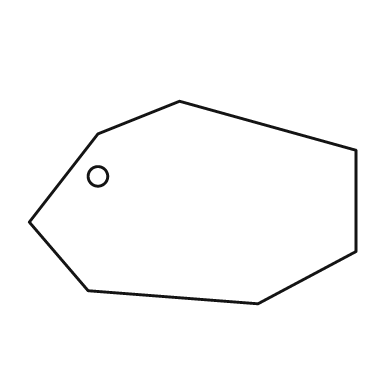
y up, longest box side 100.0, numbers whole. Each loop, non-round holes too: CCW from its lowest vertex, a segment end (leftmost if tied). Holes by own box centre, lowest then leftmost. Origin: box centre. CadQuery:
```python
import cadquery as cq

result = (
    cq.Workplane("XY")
    .moveTo(20.0, -31.0)
    .lineTo(50.0, -15.0)
    .lineTo(50.0, 16.0)
    .lineTo(-4.0, 31.0)
    .lineTo(-29.0, 21.0)
    .lineTo(-50.0, -6.0)
    .lineTo(-32.0, -27.0)
    .close()
    .moveTo(-29.0, 8.0)
    .circle(3.0)
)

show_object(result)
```